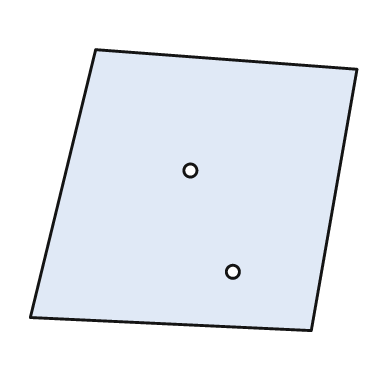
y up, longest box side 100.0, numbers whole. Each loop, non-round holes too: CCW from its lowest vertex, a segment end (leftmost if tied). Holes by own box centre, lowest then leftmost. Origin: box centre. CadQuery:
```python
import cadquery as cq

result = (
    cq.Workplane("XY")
    .moveTo(36.0, -43.0)
    .lineTo(50.0, 37.0)
    .lineTo(-30.0, 43.0)
    .lineTo(-50.0, -39.0)
    .close()
    .moveTo(12.0, -25.0)
    .circle(2.0)
    .moveTo(-1.0, 6.0)
    .circle(2.0)
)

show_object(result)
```